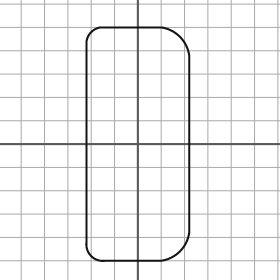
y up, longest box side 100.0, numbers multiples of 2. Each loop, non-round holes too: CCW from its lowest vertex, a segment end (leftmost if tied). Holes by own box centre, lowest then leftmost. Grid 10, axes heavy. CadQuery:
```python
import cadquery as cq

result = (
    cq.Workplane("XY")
    .moveTo(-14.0, -50.0)
    .lineTo(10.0, -50.0)
    .threePointArc((18.0, -46.0), (22.0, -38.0))
    .lineTo(22.0, 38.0)
    .threePointArc((18.0, 46.0), (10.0, 50.0))
    .lineTo(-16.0, 50.0)
    .threePointArc((-20.0, 48.0), (-22.0, 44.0))
    .lineTo(-22.0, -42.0)
    .threePointArc((-20.0, -48.0), (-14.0, -50.0))
    .close()
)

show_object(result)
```